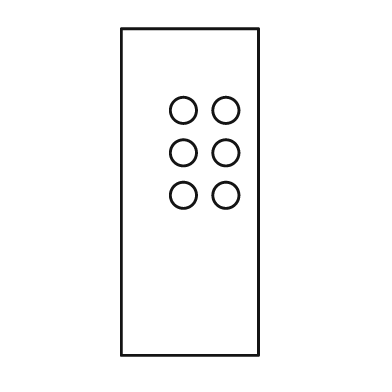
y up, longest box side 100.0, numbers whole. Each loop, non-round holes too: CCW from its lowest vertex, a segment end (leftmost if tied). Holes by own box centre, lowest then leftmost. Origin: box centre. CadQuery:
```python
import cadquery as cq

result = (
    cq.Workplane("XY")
    .moveTo(-21.0, -50.0)
    .lineTo(21.0, -50.0)
    .lineTo(21.0, 50.0)
    .lineTo(-21.0, 50.0)
    .close()
    .moveTo(-2.0, -1.0)
    .circle(4.0)
    .moveTo(11.0, -1.0)
    .circle(4.0)
    .moveTo(-2.0, 12.0)
    .circle(4.0)
    .moveTo(11.0, 12.0)
    .circle(4.0)
    .moveTo(-2.0, 25.0)
    .circle(4.0)
    .moveTo(11.0, 25.0)
    .circle(4.0)
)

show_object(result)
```